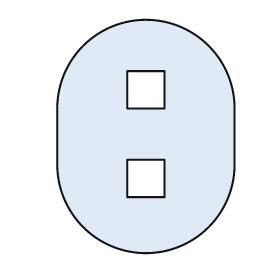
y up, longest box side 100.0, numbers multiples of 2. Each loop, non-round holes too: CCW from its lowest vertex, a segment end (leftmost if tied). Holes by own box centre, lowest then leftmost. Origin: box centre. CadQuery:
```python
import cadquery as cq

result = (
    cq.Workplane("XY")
    .moveTo(-38.0, -12.0)
    .threePointArc((0.0, -50.0), (38.0, -12.0))
    .lineTo(38.0, 12.0)
    .threePointArc((0.0, 50.0), (-38.0, 12.0))
    .close()
    .moveTo(-8.0, -26.0)
    .lineTo(8.0, -26.0)
    .lineTo(8.0, -10.0)
    .lineTo(-8.0, -10.0)
    .close()
    .moveTo(-8.0, 12.0)
    .lineTo(8.0, 12.0)
    .lineTo(8.0, 28.0)
    .lineTo(-8.0, 28.0)
    .close()
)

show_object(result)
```